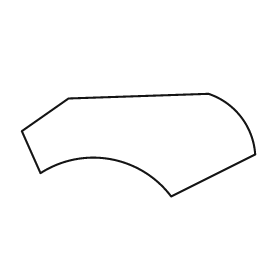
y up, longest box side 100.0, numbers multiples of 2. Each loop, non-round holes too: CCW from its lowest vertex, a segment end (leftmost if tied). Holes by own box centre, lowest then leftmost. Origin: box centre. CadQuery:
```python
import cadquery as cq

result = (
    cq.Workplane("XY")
    .moveTo(14.0, -22.0)
    .lineTo(50.0, -4.0)
    .threePointArc((44.0, 12.0), (30.0, 22.0))
    .lineTo(-30.0, 20.0)
    .lineTo(-50.0, 6.0)
    .lineTo(-42.0, -12.0)
    .threePointArc((-12.0, -6.0), (14.0, -22.0))
    .close()
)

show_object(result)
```